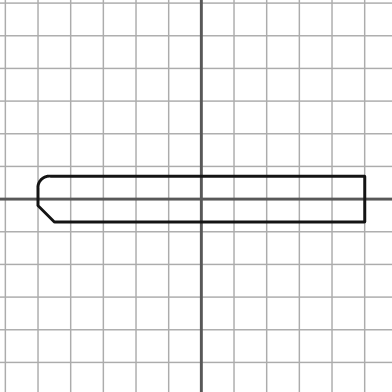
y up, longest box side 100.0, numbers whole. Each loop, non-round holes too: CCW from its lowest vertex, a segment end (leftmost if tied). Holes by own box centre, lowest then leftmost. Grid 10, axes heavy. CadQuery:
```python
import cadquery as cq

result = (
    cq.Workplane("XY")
    .moveTo(-45.0, -7.0)
    .lineTo(50.0, -7.0)
    .lineTo(50.0, 7.0)
    .lineTo(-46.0, 7.0)
    .threePointArc((-49.0, 6.0), (-50.0, 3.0))
    .lineTo(-50.0, -2.0)
    .close()
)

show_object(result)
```